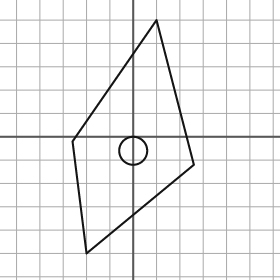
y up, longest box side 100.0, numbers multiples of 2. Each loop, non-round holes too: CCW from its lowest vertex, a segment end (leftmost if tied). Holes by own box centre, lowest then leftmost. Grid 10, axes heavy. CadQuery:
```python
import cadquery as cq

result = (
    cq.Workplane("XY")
    .moveTo(-20.0, -50.0)
    .lineTo(26.0, -12.0)
    .lineTo(10.0, 50.0)
    .lineTo(-26.0, -2.0)
    .close()
    .moveTo(0.0, -6.0)
    .circle(6.0)
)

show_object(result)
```